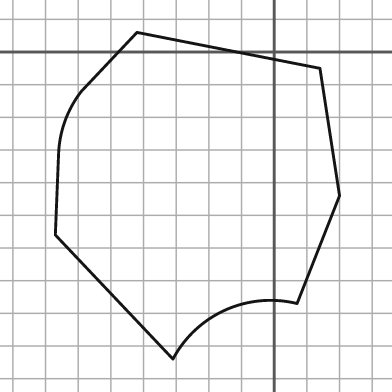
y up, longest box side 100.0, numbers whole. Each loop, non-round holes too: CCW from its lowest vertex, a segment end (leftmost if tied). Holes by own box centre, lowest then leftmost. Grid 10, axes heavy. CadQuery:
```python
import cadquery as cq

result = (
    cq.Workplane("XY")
    .moveTo(-31.0, -94.0)
    .threePointArc((-15.0, -79.0), (7.0, -77.0))
    .lineTo(20.0, -44.0)
    .lineTo(14.0, -5.0)
    .lineTo(-42.0, 6.0)
    .lineTo(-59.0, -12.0)
    .threePointArc((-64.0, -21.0), (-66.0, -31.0))
    .lineTo(-67.0, -56.0)
    .close()
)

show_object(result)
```